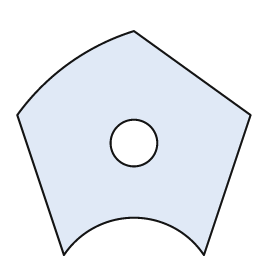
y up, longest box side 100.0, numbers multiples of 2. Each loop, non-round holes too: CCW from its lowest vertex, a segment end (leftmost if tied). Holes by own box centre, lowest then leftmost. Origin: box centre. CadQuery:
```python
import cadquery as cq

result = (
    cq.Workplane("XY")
    .moveTo(-30.0, -48.0)
    .threePointArc((0.0, -32.0), (30.0, -48.0))
    .lineTo(50.0, 12.0)
    .lineTo(0.0, 48.0)
    .threePointArc((-28.0, 34.0), (-50.0, 12.0))
    .close()
    .moveTo(0.0, 0.0)
    .circle(10.0)
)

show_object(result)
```